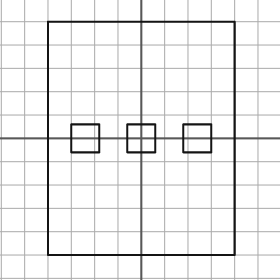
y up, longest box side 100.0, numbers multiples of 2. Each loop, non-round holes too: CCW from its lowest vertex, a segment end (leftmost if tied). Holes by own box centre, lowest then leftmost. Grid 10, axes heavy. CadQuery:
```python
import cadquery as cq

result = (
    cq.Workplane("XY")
    .moveTo(-40.0, -50.0)
    .lineTo(40.0, -50.0)
    .lineTo(40.0, 50.0)
    .lineTo(-40.0, 50.0)
    .close()
    .moveTo(-30.0, -6.0)
    .lineTo(-18.0, -6.0)
    .lineTo(-18.0, 6.0)
    .lineTo(-30.0, 6.0)
    .close()
    .moveTo(-6.0, -6.0)
    .lineTo(6.0, -6.0)
    .lineTo(6.0, 6.0)
    .lineTo(-6.0, 6.0)
    .close()
    .moveTo(18.0, -6.0)
    .lineTo(30.0, -6.0)
    .lineTo(30.0, 6.0)
    .lineTo(18.0, 6.0)
    .close()
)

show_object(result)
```